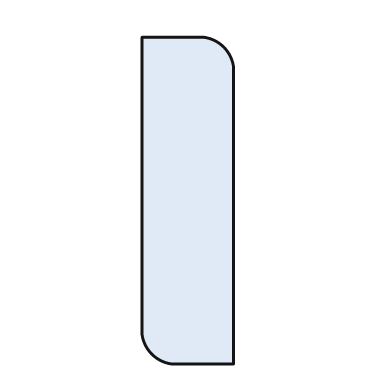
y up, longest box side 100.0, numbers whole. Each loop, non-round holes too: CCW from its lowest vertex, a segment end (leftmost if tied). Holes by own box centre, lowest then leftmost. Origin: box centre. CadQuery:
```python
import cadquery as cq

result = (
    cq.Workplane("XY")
    .moveTo(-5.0, -50.0)
    .lineTo(14.0, -50.0)
    .lineTo(14.0, 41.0)
    .threePointArc((11.0, 47.0), (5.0, 50.0))
    .lineTo(-14.0, 50.0)
    .lineTo(-14.0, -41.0)
    .threePointArc((-11.0, -47.0), (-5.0, -50.0))
    .close()
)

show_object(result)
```